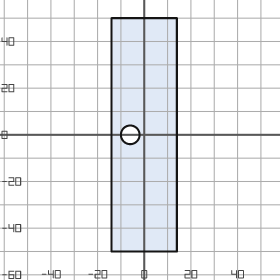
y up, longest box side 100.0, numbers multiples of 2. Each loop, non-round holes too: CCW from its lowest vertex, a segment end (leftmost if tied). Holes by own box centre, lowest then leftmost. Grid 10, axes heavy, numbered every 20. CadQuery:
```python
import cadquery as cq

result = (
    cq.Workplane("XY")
    .moveTo(-14.0, -50.0)
    .lineTo(14.0, -50.0)
    .lineTo(14.0, 50.0)
    .lineTo(-14.0, 50.0)
    .close()
    .moveTo(-6.0, 0.0)
    .circle(4.0)
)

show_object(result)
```